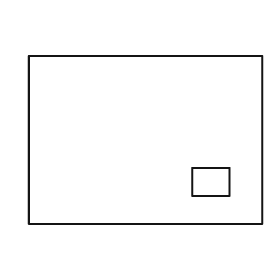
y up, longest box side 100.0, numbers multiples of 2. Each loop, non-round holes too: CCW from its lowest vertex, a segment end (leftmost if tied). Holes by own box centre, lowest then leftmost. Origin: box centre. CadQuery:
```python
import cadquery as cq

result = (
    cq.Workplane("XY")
    .moveTo(-50.0, -36.0)
    .lineTo(50.0, -36.0)
    .lineTo(50.0, 36.0)
    .lineTo(-50.0, 36.0)
    .close()
    .moveTo(20.0, -24.0)
    .lineTo(36.0, -24.0)
    .lineTo(36.0, -12.0)
    .lineTo(20.0, -12.0)
    .close()
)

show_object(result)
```